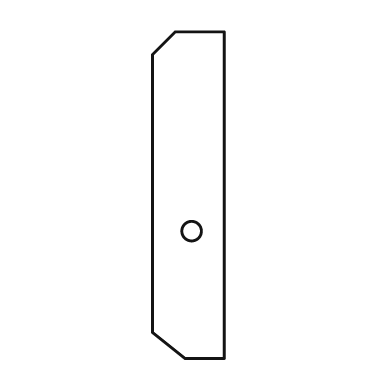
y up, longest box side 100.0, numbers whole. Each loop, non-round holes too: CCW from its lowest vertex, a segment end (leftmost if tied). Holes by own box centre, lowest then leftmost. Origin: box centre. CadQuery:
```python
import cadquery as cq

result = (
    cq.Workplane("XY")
    .moveTo(-1.0, -50.0)
    .lineTo(11.0, -50.0)
    .lineTo(11.0, 50.0)
    .lineTo(-4.0, 50.0)
    .lineTo(-11.0, 43.0)
    .lineTo(-11.0, -42.0)
    .close()
    .moveTo(1.0, -11.0)
    .circle(3.0)
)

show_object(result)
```